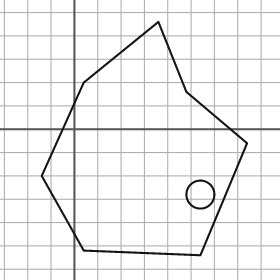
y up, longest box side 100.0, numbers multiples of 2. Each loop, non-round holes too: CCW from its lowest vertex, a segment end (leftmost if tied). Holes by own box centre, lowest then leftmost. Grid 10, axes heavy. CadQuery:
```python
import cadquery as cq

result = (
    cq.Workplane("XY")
    .moveTo(54.0, -54.0)
    .lineTo(74.0, -6.0)
    .lineTo(48.0, 16.0)
    .lineTo(36.0, 46.0)
    .lineTo(4.0, 20.0)
    .lineTo(-14.0, -20.0)
    .lineTo(4.0, -52.0)
    .close()
    .moveTo(54.0, -28.0)
    .circle(6.0)
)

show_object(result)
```